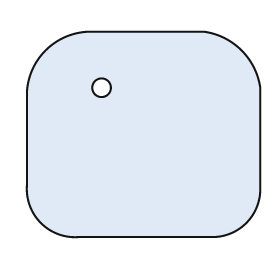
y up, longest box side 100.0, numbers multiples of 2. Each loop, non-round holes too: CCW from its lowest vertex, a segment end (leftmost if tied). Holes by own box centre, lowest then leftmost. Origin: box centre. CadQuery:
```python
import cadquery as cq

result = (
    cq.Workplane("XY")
    .moveTo(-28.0, -44.0)
    .lineTo(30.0, -44.0)
    .threePointArc((44.0, -38.0), (50.0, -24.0))
    .lineTo(50.0, 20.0)
    .threePointArc((42.0, 36.0), (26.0, 44.0))
    .lineTo(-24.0, 44.0)
    .threePointArc((-42.0, 36.0), (-50.0, 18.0))
    .lineTo(-50.0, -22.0)
    .threePointArc((-44.0, -38.0), (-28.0, -44.0))
    .close()
    .moveTo(-18.0, 20.0)
    .circle(4.0)
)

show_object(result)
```